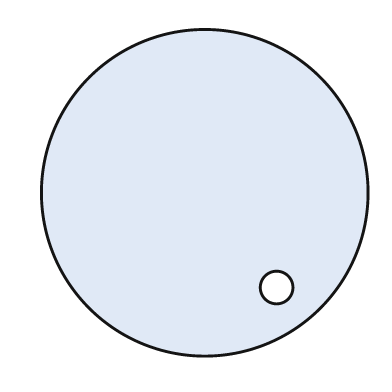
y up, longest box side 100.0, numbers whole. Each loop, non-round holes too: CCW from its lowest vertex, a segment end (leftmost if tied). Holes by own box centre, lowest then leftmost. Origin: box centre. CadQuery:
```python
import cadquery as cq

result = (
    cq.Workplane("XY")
    .moveTo(0.0, 0.0)
    .circle(50.0)
    .moveTo(22.0, -29.0)
    .circle(5.0)
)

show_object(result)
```